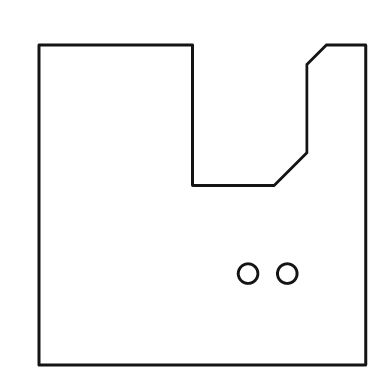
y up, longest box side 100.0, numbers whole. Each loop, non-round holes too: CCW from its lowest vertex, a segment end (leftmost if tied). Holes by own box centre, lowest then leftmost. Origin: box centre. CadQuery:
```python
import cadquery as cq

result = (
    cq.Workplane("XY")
    .moveTo(-50.0, -49.0)
    .lineTo(50.0, -49.0)
    .lineTo(50.0, 49.0)
    .lineTo(38.0, 49.0)
    .lineTo(32.0, 43.0)
    .lineTo(32.0, 16.0)
    .lineTo(22.0, 6.0)
    .lineTo(-3.0, 6.0)
    .lineTo(-3.0, 49.0)
    .lineTo(-50.0, 49.0)
    .close()
    .moveTo(14.0, -21.0)
    .circle(3.0)
    .moveTo(26.0, -21.0)
    .circle(3.0)
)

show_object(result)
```